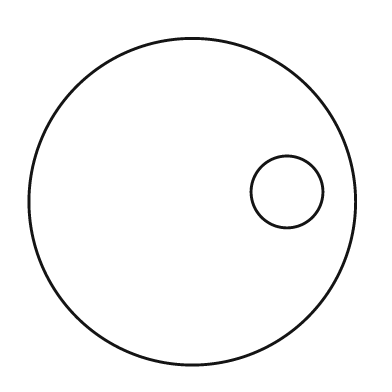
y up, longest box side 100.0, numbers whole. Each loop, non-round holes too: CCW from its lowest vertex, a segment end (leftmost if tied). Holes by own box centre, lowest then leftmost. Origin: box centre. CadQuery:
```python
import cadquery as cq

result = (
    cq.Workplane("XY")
    .moveTo(0.0, 0.0)
    .circle(50.0)
    .moveTo(29.0, 3.0)
    .circle(11.0)
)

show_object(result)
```